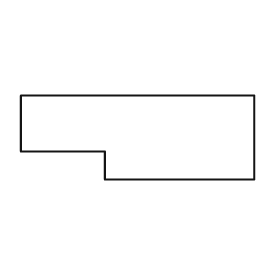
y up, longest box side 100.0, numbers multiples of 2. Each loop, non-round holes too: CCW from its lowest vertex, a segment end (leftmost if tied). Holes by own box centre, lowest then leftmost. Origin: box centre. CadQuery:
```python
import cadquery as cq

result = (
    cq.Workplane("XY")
    .moveTo(-14.0, -18.0)
    .lineTo(50.0, -18.0)
    .lineTo(50.0, 18.0)
    .lineTo(-50.0, 18.0)
    .lineTo(-50.0, -6.0)
    .lineTo(-14.0, -6.0)
    .close()
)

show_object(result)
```